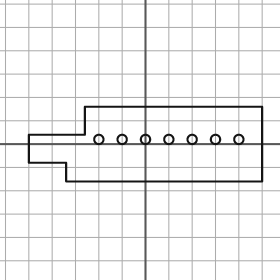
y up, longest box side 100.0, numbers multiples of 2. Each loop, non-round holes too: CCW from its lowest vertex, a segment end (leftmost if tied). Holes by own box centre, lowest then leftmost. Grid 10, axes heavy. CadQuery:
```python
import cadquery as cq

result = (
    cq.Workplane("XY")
    .moveTo(-34.0, -16.0)
    .lineTo(50.0, -16.0)
    .lineTo(50.0, 16.0)
    .lineTo(-26.0, 16.0)
    .lineTo(-26.0, 4.0)
    .lineTo(-50.0, 4.0)
    .lineTo(-50.0, -8.0)
    .lineTo(-34.0, -8.0)
    .close()
    .moveTo(-20.0, 2.0)
    .circle(2.0)
    .moveTo(-10.0, 2.0)
    .circle(2.0)
    .moveTo(0.0, 2.0)
    .circle(2.0)
    .moveTo(10.0, 2.0)
    .circle(2.0)
    .moveTo(20.0, 2.0)
    .circle(2.0)
    .moveTo(30.0, 2.0)
    .circle(2.0)
    .moveTo(40.0, 2.0)
    .circle(2.0)
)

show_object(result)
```